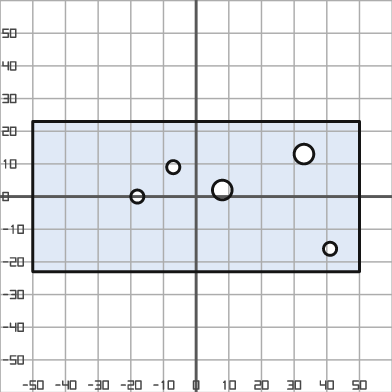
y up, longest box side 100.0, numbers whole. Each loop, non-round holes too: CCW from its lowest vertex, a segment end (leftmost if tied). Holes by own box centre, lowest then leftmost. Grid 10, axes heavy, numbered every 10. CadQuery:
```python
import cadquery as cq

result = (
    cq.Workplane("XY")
    .moveTo(-50.0, -23.0)
    .lineTo(50.0, -23.0)
    .lineTo(50.0, 23.0)
    .lineTo(-50.0, 23.0)
    .close()
    .moveTo(41.0, -16.0)
    .circle(2.0)
    .moveTo(-18.0, 0.0)
    .circle(2.0)
    .moveTo(8.0, 2.0)
    .circle(3.0)
    .moveTo(-7.0, 9.0)
    .circle(2.0)
    .moveTo(33.0, 13.0)
    .circle(3.0)
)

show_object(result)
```